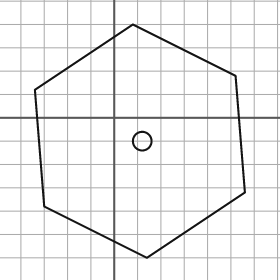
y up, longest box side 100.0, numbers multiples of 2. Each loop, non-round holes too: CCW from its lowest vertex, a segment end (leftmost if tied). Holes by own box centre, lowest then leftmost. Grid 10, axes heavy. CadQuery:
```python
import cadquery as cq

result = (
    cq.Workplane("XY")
    .moveTo(14.0, -60.0)
    .lineTo(56.0, -32.0)
    .lineTo(52.0, 18.0)
    .lineTo(8.0, 40.0)
    .lineTo(-34.0, 12.0)
    .lineTo(-30.0, -38.0)
    .close()
    .moveTo(12.0, -10.0)
    .circle(4.0)
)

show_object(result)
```